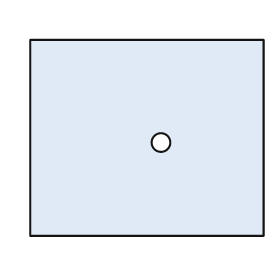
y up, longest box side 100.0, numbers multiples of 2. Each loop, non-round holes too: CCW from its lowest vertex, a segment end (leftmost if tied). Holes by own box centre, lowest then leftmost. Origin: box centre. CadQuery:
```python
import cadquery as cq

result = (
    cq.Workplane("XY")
    .moveTo(-50.0, -42.0)
    .lineTo(50.0, -42.0)
    .lineTo(50.0, 42.0)
    .lineTo(-50.0, 42.0)
    .close()
    .moveTo(6.0, -2.0)
    .circle(4.0)
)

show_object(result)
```